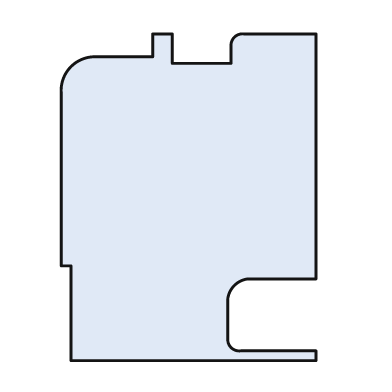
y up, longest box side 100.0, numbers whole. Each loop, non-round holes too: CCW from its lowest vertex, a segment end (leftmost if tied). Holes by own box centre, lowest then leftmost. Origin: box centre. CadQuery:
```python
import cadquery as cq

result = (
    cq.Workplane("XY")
    .moveTo(-36.0, -50.0)
    .lineTo(39.0, -50.0)
    .lineTo(39.0, -47.0)
    .lineTo(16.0, -47.0)
    .threePointArc((13.0, -46.0), (12.0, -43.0))
    .lineTo(12.0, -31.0)
    .threePointArc((14.0, -27.0), (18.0, -25.0))
    .lineTo(39.0, -25.0)
    .lineTo(39.0, 50.0)
    .lineTo(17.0, 50.0)
    .threePointArc((14.0, 49.0), (13.0, 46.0))
    .lineTo(13.0, 41.0)
    .lineTo(-5.0, 41.0)
    .lineTo(-5.0, 50.0)
    .lineTo(-11.0, 50.0)
    .lineTo(-11.0, 43.0)
    .lineTo(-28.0, 43.0)
    .threePointArc((-36.0, 40.0), (-39.0, 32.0))
    .lineTo(-39.0, -21.0)
    .lineTo(-36.0, -21.0)
    .close()
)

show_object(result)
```